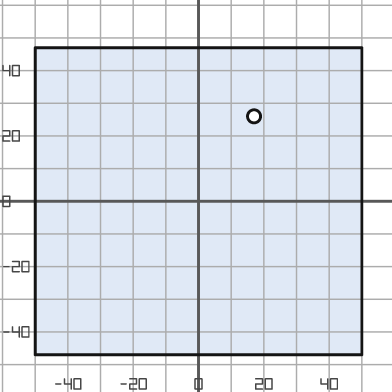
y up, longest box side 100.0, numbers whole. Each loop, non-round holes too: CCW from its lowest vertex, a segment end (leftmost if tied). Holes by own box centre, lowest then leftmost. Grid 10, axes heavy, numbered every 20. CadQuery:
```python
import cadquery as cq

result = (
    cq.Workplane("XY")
    .moveTo(-50.0, -47.0)
    .lineTo(50.0, -47.0)
    .lineTo(50.0, 47.0)
    .lineTo(-50.0, 47.0)
    .close()
    .moveTo(17.0, 26.0)
    .circle(2.0)
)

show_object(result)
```